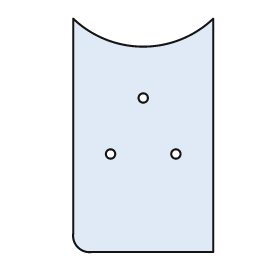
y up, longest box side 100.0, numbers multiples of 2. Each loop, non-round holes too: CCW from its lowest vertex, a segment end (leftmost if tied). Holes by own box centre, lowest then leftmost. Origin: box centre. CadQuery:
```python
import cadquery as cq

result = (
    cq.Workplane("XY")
    .moveTo(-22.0, -50.0)
    .lineTo(30.0, -50.0)
    .lineTo(30.0, 50.0)
    .threePointArc((0.0, 38.0), (-30.0, 50.0))
    .lineTo(-30.0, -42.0)
    .threePointArc((-28.0, -48.0), (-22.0, -50.0))
    .close()
    .moveTo(-14.0, -8.0)
    .circle(2.0)
    .moveTo(14.0, -8.0)
    .circle(2.0)
    .moveTo(0.0, 16.0)
    .circle(2.0)
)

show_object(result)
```